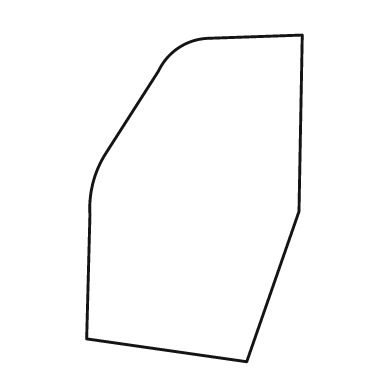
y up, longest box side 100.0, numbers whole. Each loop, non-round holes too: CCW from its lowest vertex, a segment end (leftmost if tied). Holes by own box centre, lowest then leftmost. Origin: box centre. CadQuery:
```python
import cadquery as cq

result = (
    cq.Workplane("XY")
    .moveTo(16.0, -50.0)
    .lineTo(32.0, -4.0)
    .lineTo(33.0, 50.0)
    .lineTo(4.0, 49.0)
    .threePointArc((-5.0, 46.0), (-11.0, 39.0))
    .lineTo(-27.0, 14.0)
    .threePointArc((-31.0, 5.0), (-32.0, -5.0))
    .lineTo(-33.0, -43.0)
    .close()
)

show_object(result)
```